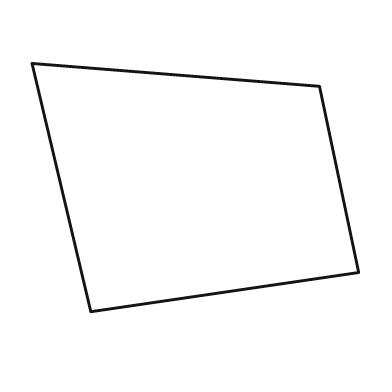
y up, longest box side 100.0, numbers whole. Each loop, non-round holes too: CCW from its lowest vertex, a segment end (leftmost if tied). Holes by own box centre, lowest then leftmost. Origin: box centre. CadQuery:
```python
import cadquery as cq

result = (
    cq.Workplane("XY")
    .moveTo(-32.0, -38.0)
    .lineTo(50.0, -26.0)
    .lineTo(38.0, 31.0)
    .lineTo(-50.0, 38.0)
    .close()
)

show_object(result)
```